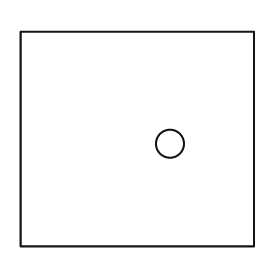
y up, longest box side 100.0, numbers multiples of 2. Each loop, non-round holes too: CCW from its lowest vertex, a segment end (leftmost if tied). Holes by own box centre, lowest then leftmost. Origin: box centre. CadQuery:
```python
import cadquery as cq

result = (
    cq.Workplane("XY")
    .moveTo(-50.0, -46.0)
    .lineTo(50.0, -46.0)
    .lineTo(50.0, 46.0)
    .lineTo(-50.0, 46.0)
    .close()
    .moveTo(14.0, -2.0)
    .circle(6.0)
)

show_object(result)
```